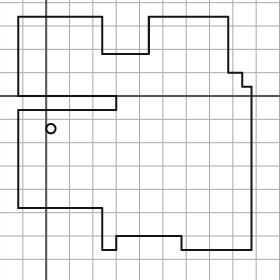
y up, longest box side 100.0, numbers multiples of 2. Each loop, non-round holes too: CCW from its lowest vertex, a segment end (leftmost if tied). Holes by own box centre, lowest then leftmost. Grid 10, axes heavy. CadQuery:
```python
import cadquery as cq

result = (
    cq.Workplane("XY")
    .moveTo(24.0, -66.0)
    .lineTo(30.0, -66.0)
    .lineTo(30.0, -60.0)
    .lineTo(58.0, -60.0)
    .lineTo(58.0, -66.0)
    .lineTo(88.0, -66.0)
    .lineTo(88.0, 4.0)
    .lineTo(84.0, 4.0)
    .lineTo(84.0, 10.0)
    .lineTo(78.0, 10.0)
    .lineTo(78.0, 34.0)
    .lineTo(44.0, 34.0)
    .lineTo(44.0, 18.0)
    .lineTo(24.0, 18.0)
    .lineTo(24.0, 34.0)
    .lineTo(-12.0, 34.0)
    .lineTo(-12.0, 0.0)
    .lineTo(30.0, 0.0)
    .lineTo(30.0, -6.0)
    .lineTo(-12.0, -6.0)
    .lineTo(-12.0, -48.0)
    .lineTo(24.0, -48.0)
    .close()
    .moveTo(2.0, -14.0)
    .circle(2.0)
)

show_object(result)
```